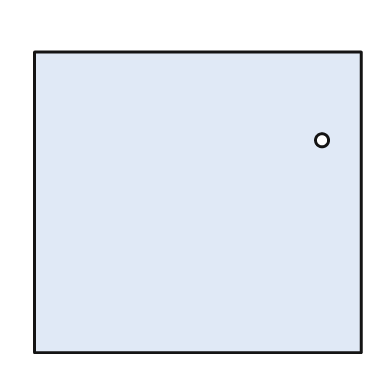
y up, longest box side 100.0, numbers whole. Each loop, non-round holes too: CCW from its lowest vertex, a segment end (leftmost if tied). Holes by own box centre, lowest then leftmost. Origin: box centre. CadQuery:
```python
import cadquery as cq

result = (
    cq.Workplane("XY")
    .moveTo(-50.0, -46.0)
    .lineTo(50.0, -46.0)
    .lineTo(50.0, 46.0)
    .lineTo(-50.0, 46.0)
    .close()
    .moveTo(38.0, 19.0)
    .circle(2.0)
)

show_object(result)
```